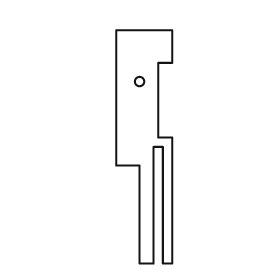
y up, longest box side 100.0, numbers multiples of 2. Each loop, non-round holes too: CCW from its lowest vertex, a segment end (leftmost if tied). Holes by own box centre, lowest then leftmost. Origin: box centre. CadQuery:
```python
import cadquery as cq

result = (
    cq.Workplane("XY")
    .moveTo(-2.0, -50.0)
    .lineTo(4.0, -50.0)
    .lineTo(4.0, 0.0)
    .lineTo(8.0, 0.0)
    .lineTo(8.0, -50.0)
    .lineTo(12.0, -50.0)
    .lineTo(12.0, 4.0)
    .lineTo(6.0, 4.0)
    .lineTo(6.0, 36.0)
    .lineTo(12.0, 36.0)
    .lineTo(12.0, 50.0)
    .lineTo(-12.0, 50.0)
    .lineTo(-12.0, -8.0)
    .lineTo(-2.0, -8.0)
    .close()
    .moveTo(-2.0, 28.0)
    .circle(2.0)
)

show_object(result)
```